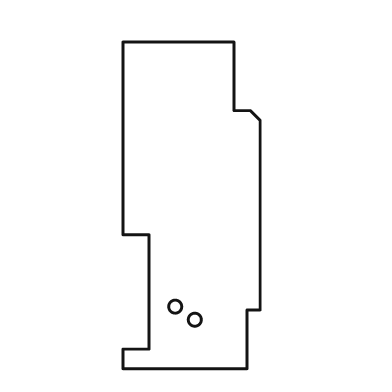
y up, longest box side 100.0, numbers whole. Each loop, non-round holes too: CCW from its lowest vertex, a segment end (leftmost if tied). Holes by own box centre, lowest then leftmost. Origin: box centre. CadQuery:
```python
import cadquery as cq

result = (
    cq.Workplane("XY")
    .moveTo(-21.0, -50.0)
    .lineTo(17.0, -50.0)
    .lineTo(17.0, -32.0)
    .lineTo(21.0, -32.0)
    .lineTo(21.0, 26.0)
    .lineTo(18.0, 29.0)
    .lineTo(13.0, 29.0)
    .lineTo(13.0, 50.0)
    .lineTo(-21.0, 50.0)
    .lineTo(-21.0, -9.0)
    .lineTo(-13.0, -9.0)
    .lineTo(-13.0, -44.0)
    .lineTo(-21.0, -44.0)
    .close()
    .moveTo(1.0, -35.0)
    .circle(2.0)
    .moveTo(-5.0, -31.0)
    .circle(2.0)
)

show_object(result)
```